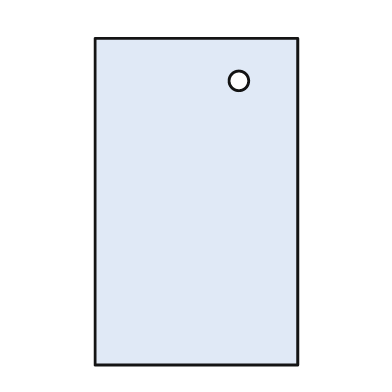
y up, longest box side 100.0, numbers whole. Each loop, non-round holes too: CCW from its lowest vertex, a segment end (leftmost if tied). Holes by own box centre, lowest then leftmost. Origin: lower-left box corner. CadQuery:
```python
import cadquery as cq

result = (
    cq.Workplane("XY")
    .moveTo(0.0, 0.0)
    .lineTo(62.0, 0.0)
    .lineTo(62.0, 100.0)
    .lineTo(0.0, 100.0)
    .close()
    .moveTo(44.0, 87.0)
    .circle(3.0)
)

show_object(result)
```